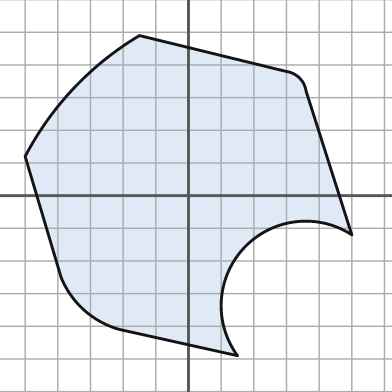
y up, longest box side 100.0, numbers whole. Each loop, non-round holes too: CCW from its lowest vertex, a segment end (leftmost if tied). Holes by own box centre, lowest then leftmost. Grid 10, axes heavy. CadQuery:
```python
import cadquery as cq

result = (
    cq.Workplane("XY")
    .moveTo(15.0, -49.0)
    .threePointArc((17.0, -16.0), (50.0, -12.0))
    .lineTo(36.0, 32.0)
    .threePointArc((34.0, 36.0), (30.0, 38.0))
    .lineTo(-15.0, 49.0)
    .threePointArc((-35.0, 33.0), (-50.0, 12.0))
    .lineTo(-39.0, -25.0)
    .threePointArc((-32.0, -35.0), (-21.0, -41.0))
    .close()
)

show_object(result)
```